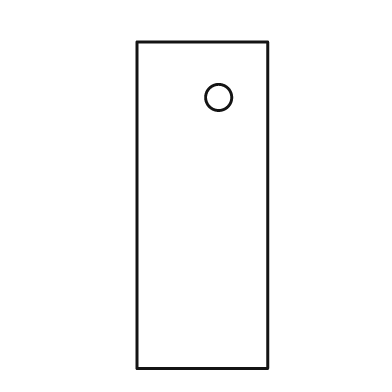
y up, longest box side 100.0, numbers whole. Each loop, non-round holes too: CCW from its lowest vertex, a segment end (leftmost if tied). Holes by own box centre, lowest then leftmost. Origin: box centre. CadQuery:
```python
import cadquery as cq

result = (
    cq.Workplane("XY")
    .moveTo(-20.0, -50.0)
    .lineTo(20.0, -50.0)
    .lineTo(20.0, 50.0)
    .lineTo(-20.0, 50.0)
    .close()
    .moveTo(5.0, 33.0)
    .circle(4.0)
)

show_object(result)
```